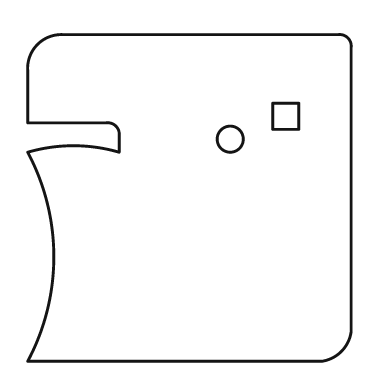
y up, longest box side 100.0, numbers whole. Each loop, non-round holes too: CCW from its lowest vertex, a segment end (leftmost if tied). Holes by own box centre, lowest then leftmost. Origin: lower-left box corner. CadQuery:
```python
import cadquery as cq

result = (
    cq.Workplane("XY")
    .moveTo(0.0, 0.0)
    .lineTo(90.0, 0.0)
    .threePointArc((96.0, 3.0), (99.0, 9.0))
    .lineTo(99.0, 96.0)
    .threePointArc((98.0, 99.0), (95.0, 100.0))
    .lineTo(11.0, 100.0)
    .threePointArc((3.0, 97.0), (0.0, 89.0))
    .lineTo(0.0, 73.0)
    .lineTo(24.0, 73.0)
    .threePointArc((27.0, 72.0), (28.0, 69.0))
    .lineTo(28.0, 64.0)
    .threePointArc((14.0, 66.0), (0.0, 64.0))
    .threePointArc((8.0, 32.0), (0.0, 0.0))
    .close()
    .moveTo(62.0, 68.0)
    .circle(4.0)
    .moveTo(75.0, 71.0)
    .lineTo(83.0, 71.0)
    .lineTo(83.0, 79.0)
    .lineTo(75.0, 79.0)
    .close()
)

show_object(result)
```